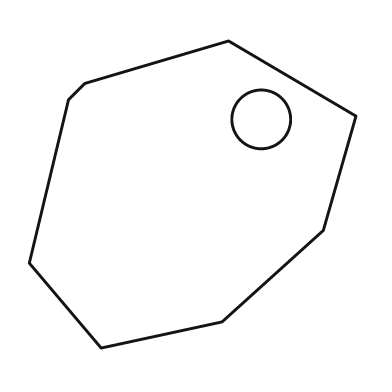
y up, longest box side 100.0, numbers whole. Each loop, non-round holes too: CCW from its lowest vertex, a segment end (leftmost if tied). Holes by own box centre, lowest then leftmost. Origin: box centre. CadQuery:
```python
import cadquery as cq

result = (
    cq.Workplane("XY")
    .moveTo(-28.0, -47.0)
    .lineTo(9.0, -39.0)
    .lineTo(40.0, -11.0)
    .lineTo(50.0, 24.0)
    .lineTo(11.0, 47.0)
    .lineTo(-33.0, 34.0)
    .lineTo(-38.0, 29.0)
    .lineTo(-50.0, -21.0)
    .close()
    .moveTo(21.0, 23.0)
    .circle(9.0)
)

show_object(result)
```